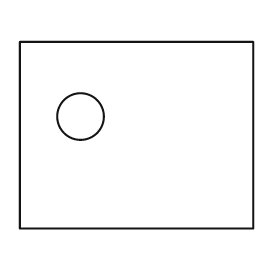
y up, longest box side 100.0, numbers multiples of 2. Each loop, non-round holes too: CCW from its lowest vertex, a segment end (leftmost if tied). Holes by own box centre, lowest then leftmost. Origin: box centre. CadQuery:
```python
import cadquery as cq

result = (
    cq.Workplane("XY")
    .moveTo(-50.0, -40.0)
    .lineTo(50.0, -40.0)
    .lineTo(50.0, 40.0)
    .lineTo(-50.0, 40.0)
    .close()
    .moveTo(-24.0, 8.0)
    .circle(10.0)
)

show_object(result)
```